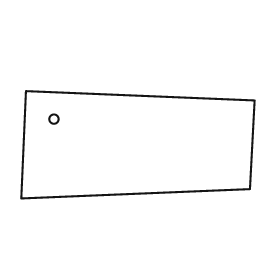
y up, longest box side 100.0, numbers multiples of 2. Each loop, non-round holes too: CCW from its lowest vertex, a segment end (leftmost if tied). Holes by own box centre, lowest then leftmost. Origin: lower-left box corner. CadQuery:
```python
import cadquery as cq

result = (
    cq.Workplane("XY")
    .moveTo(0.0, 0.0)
    .lineTo(98.0, 4.0)
    .lineTo(100.0, 42.0)
    .lineTo(2.0, 46.0)
    .close()
    .moveTo(14.0, 34.0)
    .circle(2.0)
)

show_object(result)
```